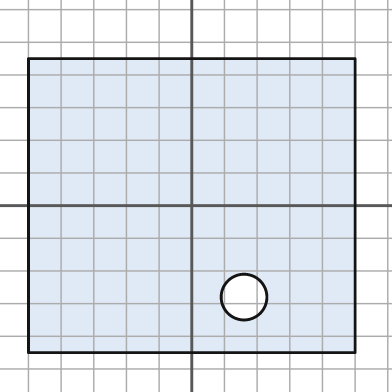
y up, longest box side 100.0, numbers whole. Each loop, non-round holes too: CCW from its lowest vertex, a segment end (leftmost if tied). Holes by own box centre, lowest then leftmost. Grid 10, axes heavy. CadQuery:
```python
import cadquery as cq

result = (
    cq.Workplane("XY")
    .moveTo(-50.0, -45.0)
    .lineTo(50.0, -45.0)
    .lineTo(50.0, 45.0)
    .lineTo(-50.0, 45.0)
    .close()
    .moveTo(16.0, -28.0)
    .circle(7.0)
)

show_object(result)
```